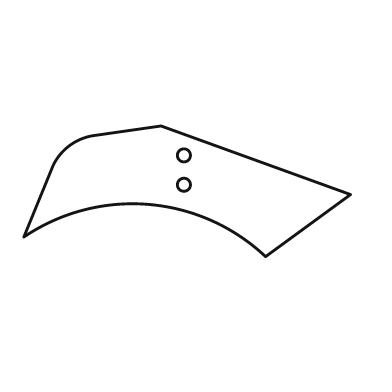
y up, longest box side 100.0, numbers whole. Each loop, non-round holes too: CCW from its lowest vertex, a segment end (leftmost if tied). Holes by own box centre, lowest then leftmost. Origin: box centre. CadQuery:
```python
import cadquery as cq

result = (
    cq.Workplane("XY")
    .moveTo(24.0, -20.0)
    .lineTo(50.0, -1.0)
    .lineTo(-8.0, 20.0)
    .lineTo(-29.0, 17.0)
    .threePointArc((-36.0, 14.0), (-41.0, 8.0))
    .lineTo(-50.0, -14.0)
    .threePointArc((-12.0, -4.0), (24.0, -20.0))
    .close()
    .moveTo(-1.0, 2.0)
    .circle(2.0)
    .moveTo(-1.0, 11.0)
    .circle(2.0)
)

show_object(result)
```